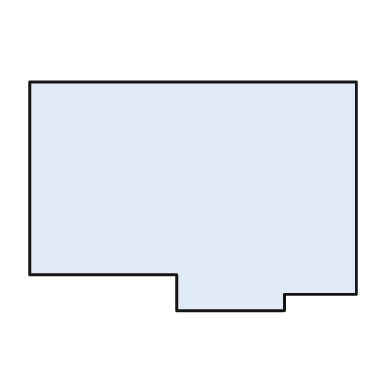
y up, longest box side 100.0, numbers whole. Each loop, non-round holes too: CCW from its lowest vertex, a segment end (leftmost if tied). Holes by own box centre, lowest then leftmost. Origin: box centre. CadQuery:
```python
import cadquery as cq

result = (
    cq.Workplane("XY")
    .moveTo(-5.0, -35.0)
    .lineTo(28.0, -35.0)
    .lineTo(28.0, -30.0)
    .lineTo(50.0, -30.0)
    .lineTo(50.0, 35.0)
    .lineTo(-50.0, 35.0)
    .lineTo(-50.0, -24.0)
    .lineTo(-5.0, -24.0)
    .close()
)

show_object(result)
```